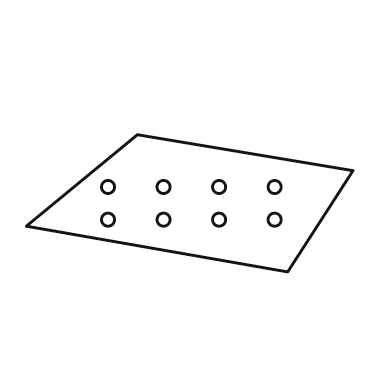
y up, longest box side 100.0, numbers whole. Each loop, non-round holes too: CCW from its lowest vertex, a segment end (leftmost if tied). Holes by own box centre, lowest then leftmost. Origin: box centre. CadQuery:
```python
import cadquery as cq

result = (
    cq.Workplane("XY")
    .moveTo(30.0, -21.0)
    .lineTo(50.0, 10.0)
    .lineTo(-16.0, 21.0)
    .lineTo(-50.0, -7.0)
    .close()
    .moveTo(-25.0, -5.0)
    .circle(2.0)
    .moveTo(-8.0, -5.0)
    .circle(2.0)
    .moveTo(9.0, -5.0)
    .circle(2.0)
    .moveTo(26.0, -5.0)
    .circle(2.0)
    .moveTo(-25.0, 5.0)
    .circle(2.0)
    .moveTo(-8.0, 5.0)
    .circle(2.0)
    .moveTo(9.0, 5.0)
    .circle(2.0)
    .moveTo(26.0, 5.0)
    .circle(2.0)
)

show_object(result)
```